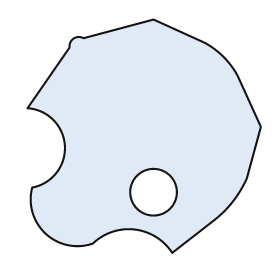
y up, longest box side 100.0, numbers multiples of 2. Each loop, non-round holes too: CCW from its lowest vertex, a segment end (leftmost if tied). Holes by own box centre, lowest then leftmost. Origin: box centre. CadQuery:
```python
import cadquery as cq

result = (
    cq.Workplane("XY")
    .moveTo(12.0, -50.0)
    .lineTo(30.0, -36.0)
    .threePointArc((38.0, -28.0), (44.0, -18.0))
    .lineTo(50.0, 4.0)
    .lineTo(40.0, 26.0)
    .threePointArc((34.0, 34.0), (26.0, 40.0))
    .lineTo(4.0, 50.0)
    .lineTo(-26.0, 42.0)
    .threePointArc((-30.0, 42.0), (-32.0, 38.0))
    .lineTo(-50.0, 12.0)
    .threePointArc((-34.0, -4.0), (-48.0, -22.0))
    .threePointArc((-42.0, -42.0), (-22.0, -46.0))
    .threePointArc((-4.0, -40.0), (12.0, -50.0))
    .close()
    .moveTo(4.0, -24.0)
    .circle(10.0)
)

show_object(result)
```